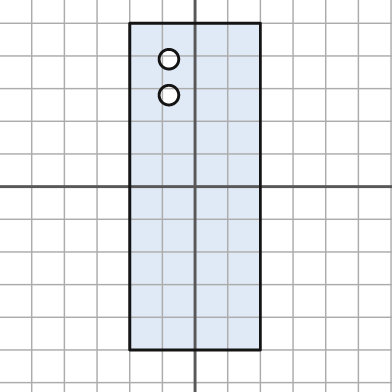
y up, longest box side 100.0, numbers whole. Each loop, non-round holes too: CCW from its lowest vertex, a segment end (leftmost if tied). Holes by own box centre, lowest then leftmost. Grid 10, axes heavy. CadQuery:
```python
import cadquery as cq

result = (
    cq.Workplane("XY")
    .moveTo(-20.0, -50.0)
    .lineTo(20.0, -50.0)
    .lineTo(20.0, 50.0)
    .lineTo(-20.0, 50.0)
    .close()
    .moveTo(-8.0, 28.0)
    .circle(3.0)
    .moveTo(-8.0, 39.0)
    .circle(3.0)
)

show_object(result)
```